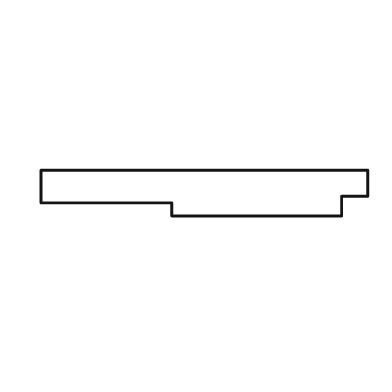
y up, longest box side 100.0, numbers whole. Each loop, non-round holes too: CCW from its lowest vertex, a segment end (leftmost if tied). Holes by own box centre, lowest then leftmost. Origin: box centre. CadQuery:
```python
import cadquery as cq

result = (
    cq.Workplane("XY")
    .moveTo(-10.0, -7.0)
    .lineTo(42.0, -7.0)
    .lineTo(42.0, -1.0)
    .lineTo(50.0, -1.0)
    .lineTo(50.0, 7.0)
    .lineTo(-50.0, 7.0)
    .lineTo(-50.0, -3.0)
    .lineTo(-10.0, -3.0)
    .close()
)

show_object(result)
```